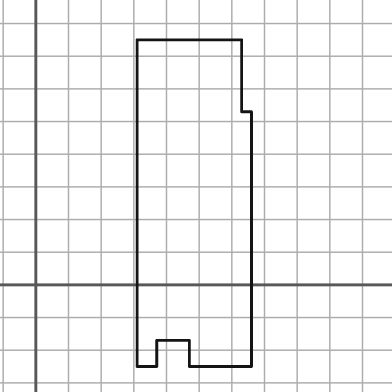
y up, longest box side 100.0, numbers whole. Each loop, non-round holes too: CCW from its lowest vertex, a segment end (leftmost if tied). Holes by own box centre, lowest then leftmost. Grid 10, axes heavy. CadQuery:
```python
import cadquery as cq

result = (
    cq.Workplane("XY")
    .moveTo(31.0, -25.0)
    .lineTo(37.0, -25.0)
    .lineTo(37.0, -17.0)
    .lineTo(47.0, -17.0)
    .lineTo(47.0, -25.0)
    .lineTo(66.0, -25.0)
    .lineTo(66.0, 53.0)
    .lineTo(63.0, 53.0)
    .lineTo(63.0, 75.0)
    .lineTo(31.0, 75.0)
    .close()
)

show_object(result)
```